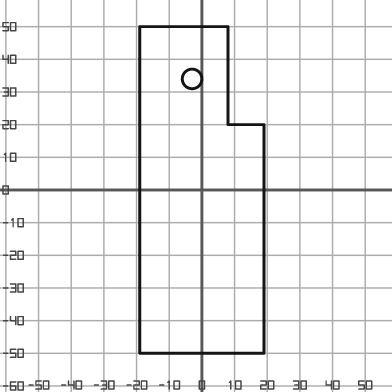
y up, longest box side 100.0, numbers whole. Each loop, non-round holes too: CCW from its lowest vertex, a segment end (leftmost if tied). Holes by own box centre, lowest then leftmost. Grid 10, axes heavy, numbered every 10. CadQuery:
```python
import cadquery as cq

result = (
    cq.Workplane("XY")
    .moveTo(-19.0, -50.0)
    .lineTo(19.0, -50.0)
    .lineTo(19.0, 20.0)
    .lineTo(8.0, 20.0)
    .lineTo(8.0, 50.0)
    .lineTo(-19.0, 50.0)
    .close()
    .moveTo(-3.0, 34.0)
    .circle(3.0)
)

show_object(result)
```